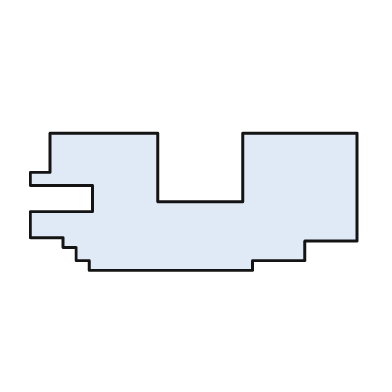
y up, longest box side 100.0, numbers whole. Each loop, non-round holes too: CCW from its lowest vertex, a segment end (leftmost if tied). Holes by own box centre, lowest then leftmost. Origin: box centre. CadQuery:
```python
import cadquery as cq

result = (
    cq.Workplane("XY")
    .moveTo(-32.0, -21.0)
    .lineTo(18.0, -21.0)
    .lineTo(18.0, -18.0)
    .lineTo(34.0, -18.0)
    .lineTo(34.0, -12.0)
    .lineTo(50.0, -12.0)
    .lineTo(50.0, 21.0)
    .lineTo(15.0, 21.0)
    .lineTo(15.0, 0.0)
    .lineTo(-11.0, 0.0)
    .lineTo(-11.0, 21.0)
    .lineTo(-44.0, 21.0)
    .lineTo(-44.0, 9.0)
    .lineTo(-50.0, 9.0)
    .lineTo(-50.0, 5.0)
    .lineTo(-31.0, 5.0)
    .lineTo(-31.0, -3.0)
    .lineTo(-50.0, -3.0)
    .lineTo(-50.0, -11.0)
    .lineTo(-40.0, -11.0)
    .lineTo(-40.0, -14.0)
    .lineTo(-36.0, -14.0)
    .lineTo(-36.0, -18.0)
    .lineTo(-32.0, -18.0)
    .close()
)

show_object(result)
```